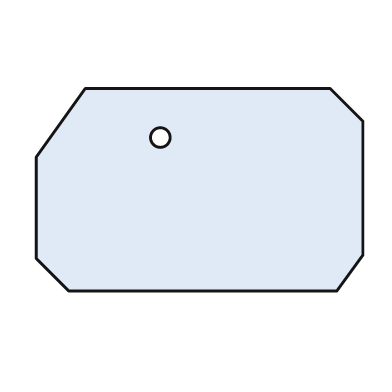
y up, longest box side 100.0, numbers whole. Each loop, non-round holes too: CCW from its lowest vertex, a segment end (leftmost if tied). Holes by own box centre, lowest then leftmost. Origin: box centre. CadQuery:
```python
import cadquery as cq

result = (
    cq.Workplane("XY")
    .moveTo(-40.0, -31.0)
    .lineTo(42.0, -31.0)
    .lineTo(50.0, -20.0)
    .lineTo(50.0, 21.0)
    .lineTo(40.0, 31.0)
    .lineTo(-35.0, 31.0)
    .lineTo(-50.0, 10.0)
    .lineTo(-50.0, -21.0)
    .close()
    .moveTo(-12.0, 16.0)
    .circle(3.0)
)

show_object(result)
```